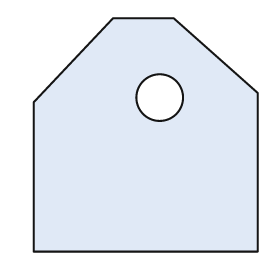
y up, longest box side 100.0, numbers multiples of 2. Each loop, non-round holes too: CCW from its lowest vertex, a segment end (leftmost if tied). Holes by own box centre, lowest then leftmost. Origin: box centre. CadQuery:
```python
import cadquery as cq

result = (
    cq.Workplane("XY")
    .moveTo(-48.0, -50.0)
    .lineTo(48.0, -50.0)
    .lineTo(48.0, 18.0)
    .lineTo(12.0, 50.0)
    .lineTo(-14.0, 50.0)
    .lineTo(-48.0, 14.0)
    .close()
    .moveTo(6.0, 16.0)
    .circle(10.0)
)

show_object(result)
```